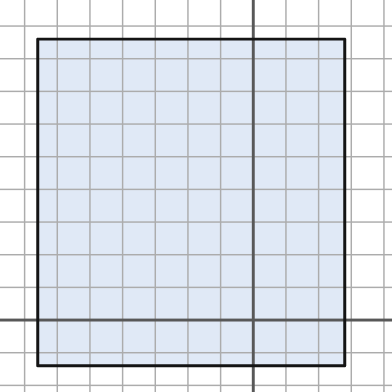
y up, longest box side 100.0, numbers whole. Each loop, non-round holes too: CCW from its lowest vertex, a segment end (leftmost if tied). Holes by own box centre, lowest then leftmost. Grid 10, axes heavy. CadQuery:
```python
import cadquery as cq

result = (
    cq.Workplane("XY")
    .moveTo(-66.0, -14.0)
    .lineTo(28.0, -14.0)
    .lineTo(28.0, 86.0)
    .lineTo(-66.0, 86.0)
    .close()
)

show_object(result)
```